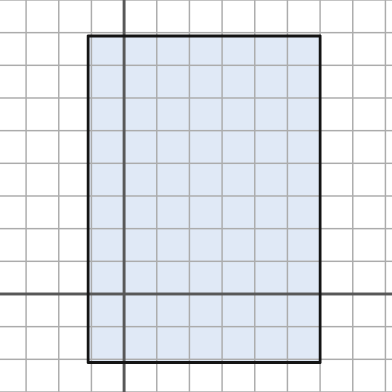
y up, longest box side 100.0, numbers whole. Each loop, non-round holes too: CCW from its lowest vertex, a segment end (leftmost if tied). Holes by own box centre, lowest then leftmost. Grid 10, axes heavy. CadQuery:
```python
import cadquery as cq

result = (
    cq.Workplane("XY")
    .moveTo(-11.0, -21.0)
    .lineTo(60.0, -21.0)
    .lineTo(60.0, 79.0)
    .lineTo(-11.0, 79.0)
    .close()
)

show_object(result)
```